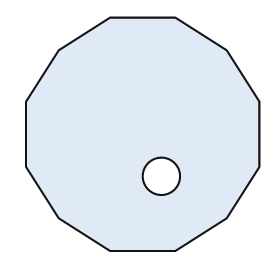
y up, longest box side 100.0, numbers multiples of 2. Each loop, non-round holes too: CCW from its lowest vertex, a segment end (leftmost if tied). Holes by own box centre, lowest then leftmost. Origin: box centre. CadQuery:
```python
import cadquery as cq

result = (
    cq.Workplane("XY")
    .moveTo(-14.0, -50.0)
    .lineTo(14.0, -50.0)
    .lineTo(36.0, -36.0)
    .lineTo(50.0, -14.0)
    .lineTo(50.0, 14.0)
    .lineTo(36.0, 36.0)
    .lineTo(14.0, 50.0)
    .lineTo(-14.0, 50.0)
    .lineTo(-36.0, 36.0)
    .lineTo(-50.0, 14.0)
    .lineTo(-50.0, -14.0)
    .lineTo(-36.0, -36.0)
    .close()
    .moveTo(8.0, -18.0)
    .circle(8.0)
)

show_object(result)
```